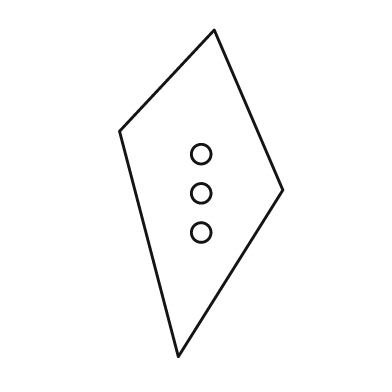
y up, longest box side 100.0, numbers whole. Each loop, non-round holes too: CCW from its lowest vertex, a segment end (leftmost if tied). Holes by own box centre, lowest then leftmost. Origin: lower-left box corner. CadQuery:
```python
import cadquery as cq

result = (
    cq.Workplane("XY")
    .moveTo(18.0, 0.0)
    .lineTo(50.0, 51.0)
    .lineTo(29.0, 100.0)
    .lineTo(0.0, 69.0)
    .close()
    .moveTo(25.0, 38.0)
    .circle(3.0)
    .moveTo(25.0, 50.0)
    .circle(3.0)
    .moveTo(25.0, 62.0)
    .circle(3.0)
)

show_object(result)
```